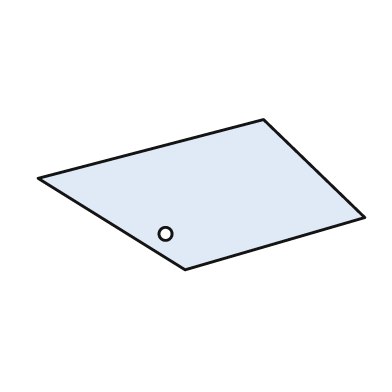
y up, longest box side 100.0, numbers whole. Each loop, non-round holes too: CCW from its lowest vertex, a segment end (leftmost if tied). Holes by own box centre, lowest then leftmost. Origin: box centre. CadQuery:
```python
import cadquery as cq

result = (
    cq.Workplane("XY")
    .moveTo(-5.0, -23.0)
    .lineTo(50.0, -7.0)
    .lineTo(19.0, 23.0)
    .lineTo(-50.0, 5.0)
    .close()
    .moveTo(-11.0, -12.0)
    .circle(2.0)
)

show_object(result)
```